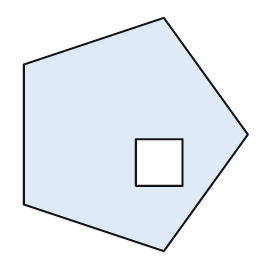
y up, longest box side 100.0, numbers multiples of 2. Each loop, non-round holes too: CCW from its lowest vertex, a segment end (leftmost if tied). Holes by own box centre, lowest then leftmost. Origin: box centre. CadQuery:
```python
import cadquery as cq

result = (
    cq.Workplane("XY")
    .moveTo(12.0, -50.0)
    .lineTo(48.0, 0.0)
    .lineTo(12.0, 50.0)
    .lineTo(-48.0, 30.0)
    .lineTo(-48.0, -30.0)
    .close()
    .moveTo(0.0, -22.0)
    .lineTo(20.0, -22.0)
    .lineTo(20.0, -2.0)
    .lineTo(0.0, -2.0)
    .close()
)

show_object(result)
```